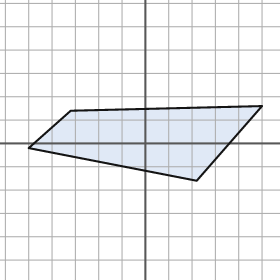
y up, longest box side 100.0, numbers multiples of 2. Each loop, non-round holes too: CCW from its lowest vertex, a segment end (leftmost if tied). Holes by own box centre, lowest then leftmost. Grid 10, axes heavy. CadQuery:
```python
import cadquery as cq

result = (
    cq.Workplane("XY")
    .moveTo(22.0, -16.0)
    .lineTo(50.0, 16.0)
    .lineTo(-32.0, 14.0)
    .lineTo(-50.0, -2.0)
    .close()
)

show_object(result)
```